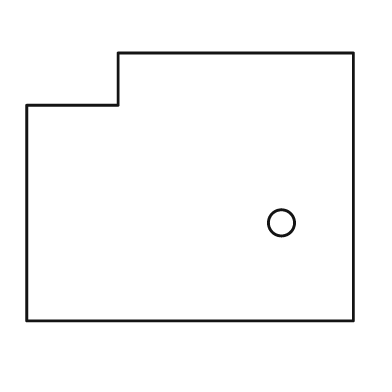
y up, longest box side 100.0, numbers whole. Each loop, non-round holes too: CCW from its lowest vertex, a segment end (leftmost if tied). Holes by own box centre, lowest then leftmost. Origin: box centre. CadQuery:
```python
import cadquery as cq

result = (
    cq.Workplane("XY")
    .moveTo(-50.0, -41.0)
    .lineTo(50.0, -41.0)
    .lineTo(50.0, 41.0)
    .lineTo(-22.0, 41.0)
    .lineTo(-22.0, 25.0)
    .lineTo(-50.0, 25.0)
    .close()
    .moveTo(28.0, -11.0)
    .circle(4.0)
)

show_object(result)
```